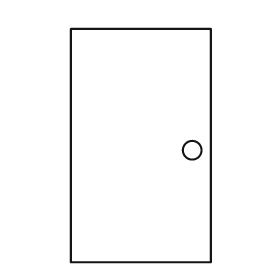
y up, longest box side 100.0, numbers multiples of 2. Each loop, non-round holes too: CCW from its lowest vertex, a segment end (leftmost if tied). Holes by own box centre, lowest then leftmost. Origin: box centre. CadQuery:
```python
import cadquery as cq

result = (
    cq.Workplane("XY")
    .moveTo(-30.0, -50.0)
    .lineTo(30.0, -50.0)
    .lineTo(30.0, 50.0)
    .lineTo(-30.0, 50.0)
    .close()
    .moveTo(22.0, -2.0)
    .circle(4.0)
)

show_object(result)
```